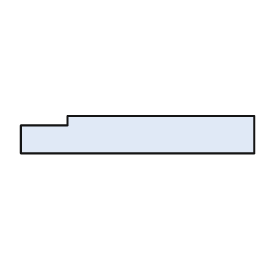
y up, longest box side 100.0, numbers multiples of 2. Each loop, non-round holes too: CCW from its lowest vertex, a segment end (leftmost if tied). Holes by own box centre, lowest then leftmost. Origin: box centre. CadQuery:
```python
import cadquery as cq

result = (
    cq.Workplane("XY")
    .moveTo(-50.0, -8.0)
    .lineTo(50.0, -8.0)
    .lineTo(50.0, 8.0)
    .lineTo(-30.0, 8.0)
    .lineTo(-30.0, 4.0)
    .lineTo(-50.0, 4.0)
    .close()
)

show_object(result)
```